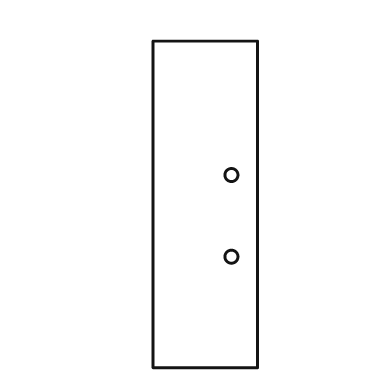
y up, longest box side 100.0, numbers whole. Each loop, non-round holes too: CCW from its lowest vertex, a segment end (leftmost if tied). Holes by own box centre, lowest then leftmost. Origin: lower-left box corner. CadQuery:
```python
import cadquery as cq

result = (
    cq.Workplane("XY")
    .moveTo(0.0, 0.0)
    .lineTo(32.0, 0.0)
    .lineTo(32.0, 100.0)
    .lineTo(0.0, 100.0)
    .close()
    .moveTo(24.0, 34.0)
    .circle(2.0)
    .moveTo(24.0, 59.0)
    .circle(2.0)
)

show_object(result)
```